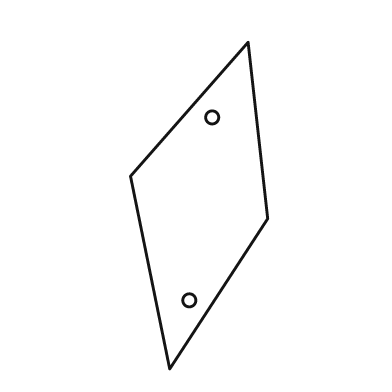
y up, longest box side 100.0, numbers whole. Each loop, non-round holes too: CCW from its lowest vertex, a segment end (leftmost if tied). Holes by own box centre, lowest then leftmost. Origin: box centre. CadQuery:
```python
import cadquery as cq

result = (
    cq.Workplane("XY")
    .moveTo(-9.0, -50.0)
    .lineTo(21.0, -4.0)
    .lineTo(15.0, 50.0)
    .lineTo(-21.0, 9.0)
    .close()
    .moveTo(-3.0, -29.0)
    .circle(2.0)
    .moveTo(4.0, 27.0)
    .circle(2.0)
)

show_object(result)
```